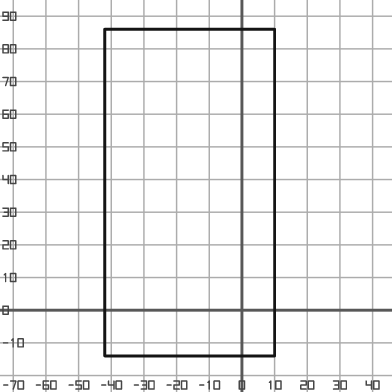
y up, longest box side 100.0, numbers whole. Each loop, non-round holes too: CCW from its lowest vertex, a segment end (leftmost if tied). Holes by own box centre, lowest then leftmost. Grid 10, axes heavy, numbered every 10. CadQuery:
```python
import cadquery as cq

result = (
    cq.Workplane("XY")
    .moveTo(-42.0, -14.0)
    .lineTo(10.0, -14.0)
    .lineTo(10.0, 86.0)
    .lineTo(-42.0, 86.0)
    .close()
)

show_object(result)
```